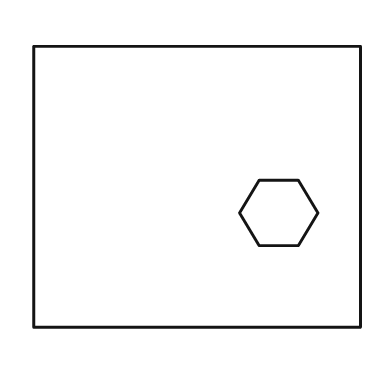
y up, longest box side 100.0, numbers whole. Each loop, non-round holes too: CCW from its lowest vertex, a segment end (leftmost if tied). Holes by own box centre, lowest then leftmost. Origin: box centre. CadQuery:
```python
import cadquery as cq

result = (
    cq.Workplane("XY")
    .moveTo(-50.0, -43.0)
    .lineTo(50.0, -43.0)
    .lineTo(50.0, 43.0)
    .lineTo(-50.0, 43.0)
    .close()
    .moveTo(19.0, -18.0)
    .lineTo(31.0, -18.0)
    .lineTo(37.0, -8.0)
    .lineTo(31.0, 2.0)
    .lineTo(19.0, 2.0)
    .lineTo(13.0, -8.0)
    .close()
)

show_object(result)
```